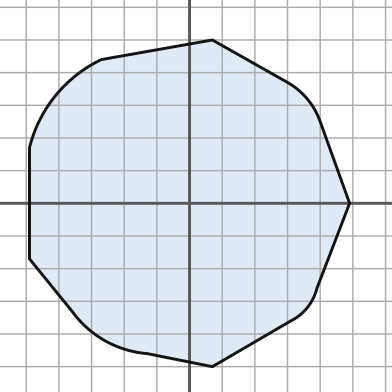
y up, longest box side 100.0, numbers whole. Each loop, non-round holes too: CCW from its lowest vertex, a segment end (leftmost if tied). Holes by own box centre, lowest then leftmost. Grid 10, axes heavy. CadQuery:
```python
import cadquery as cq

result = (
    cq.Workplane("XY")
    .moveTo(7.0, -50.0)
    .lineTo(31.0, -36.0)
    .threePointArc((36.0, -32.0), (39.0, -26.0))
    .lineTo(49.0, 0.0)
    .lineTo(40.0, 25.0)
    .threePointArc((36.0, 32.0), (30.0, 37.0))
    .lineTo(7.0, 50.0)
    .lineTo(-27.0, 44.0)
    .threePointArc((-41.0, 33.0), (-49.0, 17.0))
    .lineTo(-49.0, -17.0)
    .lineTo(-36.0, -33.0)
    .threePointArc((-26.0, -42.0), (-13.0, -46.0))
    .close()
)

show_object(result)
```